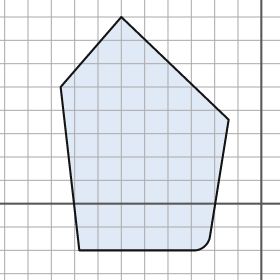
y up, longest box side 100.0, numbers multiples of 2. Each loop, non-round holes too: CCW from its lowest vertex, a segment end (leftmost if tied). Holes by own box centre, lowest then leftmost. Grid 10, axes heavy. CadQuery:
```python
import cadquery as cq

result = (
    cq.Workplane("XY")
    .moveTo(-78.0, -20.0)
    .lineTo(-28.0, -20.0)
    .threePointArc((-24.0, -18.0), (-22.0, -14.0))
    .lineTo(-14.0, 36.0)
    .lineTo(-60.0, 80.0)
    .lineTo(-86.0, 50.0)
    .close()
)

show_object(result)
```